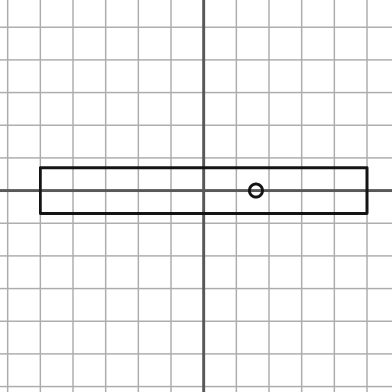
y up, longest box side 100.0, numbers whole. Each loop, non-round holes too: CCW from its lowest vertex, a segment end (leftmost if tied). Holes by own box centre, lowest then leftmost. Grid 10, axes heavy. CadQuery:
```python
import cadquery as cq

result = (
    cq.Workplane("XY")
    .moveTo(-50.0, -7.0)
    .lineTo(50.0, -7.0)
    .lineTo(50.0, 7.0)
    .lineTo(-50.0, 7.0)
    .close()
    .moveTo(16.0, 0.0)
    .circle(2.0)
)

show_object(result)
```